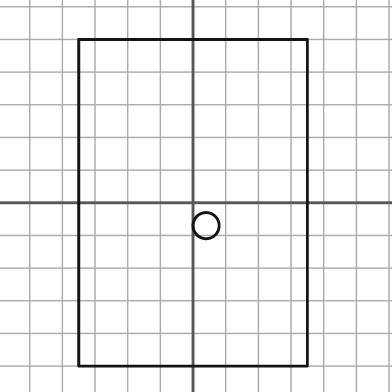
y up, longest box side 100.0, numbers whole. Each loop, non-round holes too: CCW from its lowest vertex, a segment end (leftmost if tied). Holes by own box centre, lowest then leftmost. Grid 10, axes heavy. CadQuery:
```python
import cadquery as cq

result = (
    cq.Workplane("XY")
    .moveTo(-35.0, -50.0)
    .lineTo(35.0, -50.0)
    .lineTo(35.0, 50.0)
    .lineTo(-35.0, 50.0)
    .close()
    .moveTo(4.0, -7.0)
    .circle(4.0)
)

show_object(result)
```